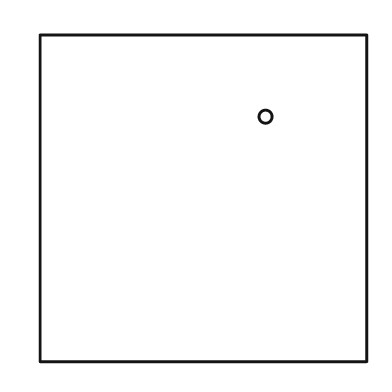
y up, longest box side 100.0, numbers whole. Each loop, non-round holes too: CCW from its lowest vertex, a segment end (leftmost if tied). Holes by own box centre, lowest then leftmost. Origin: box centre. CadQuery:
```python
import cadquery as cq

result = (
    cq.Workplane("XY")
    .moveTo(-50.0, -50.0)
    .lineTo(50.0, -50.0)
    .lineTo(50.0, 50.0)
    .lineTo(-50.0, 50.0)
    .close()
    .moveTo(19.0, 25.0)
    .circle(2.0)
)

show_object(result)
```